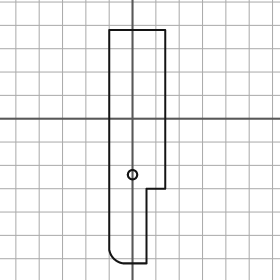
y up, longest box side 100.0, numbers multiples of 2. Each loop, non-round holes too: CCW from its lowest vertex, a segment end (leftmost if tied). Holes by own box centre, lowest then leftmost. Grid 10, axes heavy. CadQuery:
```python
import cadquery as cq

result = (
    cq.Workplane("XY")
    .moveTo(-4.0, -62.0)
    .lineTo(6.0, -62.0)
    .lineTo(6.0, -30.0)
    .lineTo(14.0, -30.0)
    .lineTo(14.0, 38.0)
    .lineTo(-10.0, 38.0)
    .lineTo(-10.0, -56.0)
    .threePointArc((-8.0, -60.0), (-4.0, -62.0))
    .close()
    .moveTo(0.0, -24.0)
    .circle(2.0)
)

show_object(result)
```